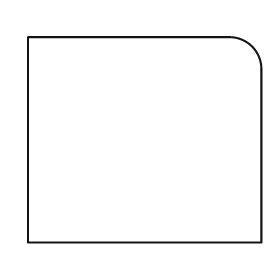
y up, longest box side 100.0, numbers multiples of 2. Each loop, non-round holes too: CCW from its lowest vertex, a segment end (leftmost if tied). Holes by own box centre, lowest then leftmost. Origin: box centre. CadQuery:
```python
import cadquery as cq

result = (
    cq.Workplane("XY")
    .moveTo(-50.0, -44.0)
    .lineTo(50.0, -44.0)
    .lineTo(50.0, 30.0)
    .threePointArc((46.0, 40.0), (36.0, 44.0))
    .lineTo(-50.0, 44.0)
    .close()
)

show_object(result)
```